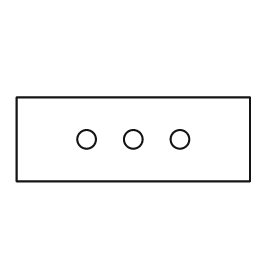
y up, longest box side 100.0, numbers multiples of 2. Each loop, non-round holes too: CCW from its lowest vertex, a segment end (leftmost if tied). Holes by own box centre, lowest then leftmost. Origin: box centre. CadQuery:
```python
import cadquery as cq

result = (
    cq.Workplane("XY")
    .moveTo(-50.0, -18.0)
    .lineTo(50.0, -18.0)
    .lineTo(50.0, 18.0)
    .lineTo(-50.0, 18.0)
    .close()
    .moveTo(-20.0, 0.0)
    .circle(4.0)
    .moveTo(0.0, 0.0)
    .circle(4.0)
    .moveTo(20.0, 0.0)
    .circle(4.0)
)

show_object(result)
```